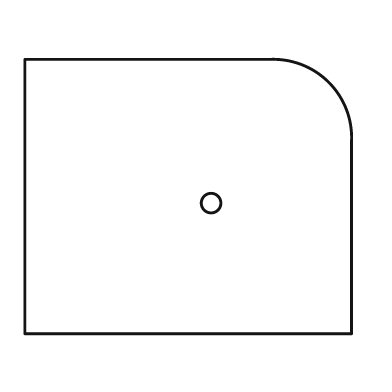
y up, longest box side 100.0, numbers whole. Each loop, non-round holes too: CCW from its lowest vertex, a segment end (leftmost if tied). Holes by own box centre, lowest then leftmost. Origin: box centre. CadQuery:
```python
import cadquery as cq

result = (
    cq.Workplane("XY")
    .moveTo(-50.0, -42.0)
    .lineTo(50.0, -42.0)
    .lineTo(50.0, 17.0)
    .threePointArc((43.0, 35.0), (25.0, 42.0))
    .lineTo(-50.0, 42.0)
    .close()
    .moveTo(7.0, -2.0)
    .circle(3.0)
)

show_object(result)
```